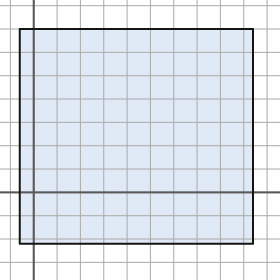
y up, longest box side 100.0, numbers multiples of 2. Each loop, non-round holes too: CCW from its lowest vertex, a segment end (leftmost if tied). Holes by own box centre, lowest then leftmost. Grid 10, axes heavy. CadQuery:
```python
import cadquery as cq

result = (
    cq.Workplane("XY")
    .moveTo(-6.0, -22.0)
    .lineTo(94.0, -22.0)
    .lineTo(94.0, 70.0)
    .lineTo(-6.0, 70.0)
    .close()
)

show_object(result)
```